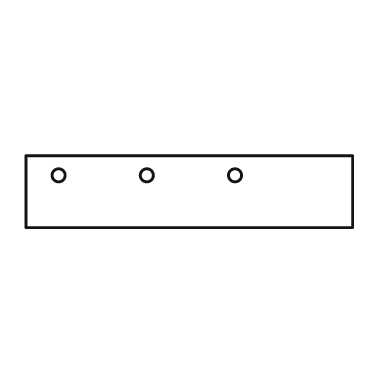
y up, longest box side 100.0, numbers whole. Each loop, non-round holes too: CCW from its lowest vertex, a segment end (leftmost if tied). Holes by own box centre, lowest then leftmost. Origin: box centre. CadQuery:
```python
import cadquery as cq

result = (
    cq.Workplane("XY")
    .moveTo(-50.0, -11.0)
    .lineTo(50.0, -11.0)
    .lineTo(50.0, 11.0)
    .lineTo(-50.0, 11.0)
    .close()
    .moveTo(-40.0, 5.0)
    .circle(2.0)
    .moveTo(-13.0, 5.0)
    .circle(2.0)
    .moveTo(14.0, 5.0)
    .circle(2.0)
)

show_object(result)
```